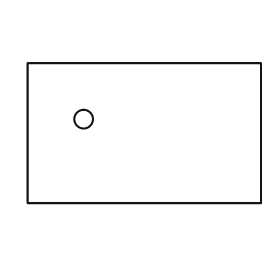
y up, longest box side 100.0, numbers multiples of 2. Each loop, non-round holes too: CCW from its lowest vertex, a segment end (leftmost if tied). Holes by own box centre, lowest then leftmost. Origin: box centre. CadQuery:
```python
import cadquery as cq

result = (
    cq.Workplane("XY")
    .moveTo(-50.0, -30.0)
    .lineTo(50.0, -30.0)
    .lineTo(50.0, 30.0)
    .lineTo(-50.0, 30.0)
    .close()
    .moveTo(-26.0, 6.0)
    .circle(4.0)
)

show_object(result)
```